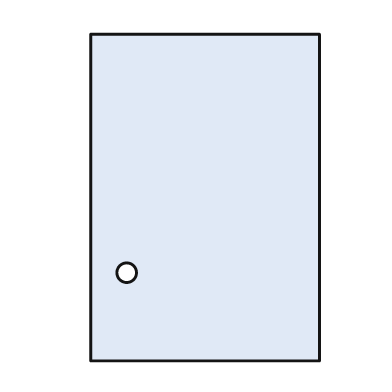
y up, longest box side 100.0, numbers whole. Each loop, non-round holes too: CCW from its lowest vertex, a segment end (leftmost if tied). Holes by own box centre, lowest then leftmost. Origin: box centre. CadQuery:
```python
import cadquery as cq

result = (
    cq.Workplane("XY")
    .moveTo(-35.0, -50.0)
    .lineTo(35.0, -50.0)
    .lineTo(35.0, 50.0)
    .lineTo(-35.0, 50.0)
    .close()
    .moveTo(-24.0, -23.0)
    .circle(3.0)
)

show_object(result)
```